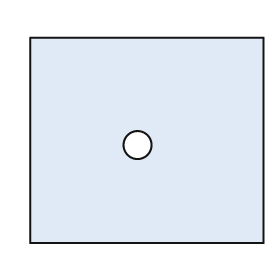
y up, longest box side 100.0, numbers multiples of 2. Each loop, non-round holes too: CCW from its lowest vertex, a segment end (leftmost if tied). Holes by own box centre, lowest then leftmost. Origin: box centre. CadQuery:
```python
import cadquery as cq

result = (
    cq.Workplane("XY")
    .moveTo(-50.0, -44.0)
    .lineTo(50.0, -44.0)
    .lineTo(50.0, 44.0)
    .lineTo(-50.0, 44.0)
    .close()
    .moveTo(-4.0, -2.0)
    .circle(6.0)
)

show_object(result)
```